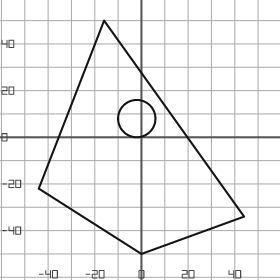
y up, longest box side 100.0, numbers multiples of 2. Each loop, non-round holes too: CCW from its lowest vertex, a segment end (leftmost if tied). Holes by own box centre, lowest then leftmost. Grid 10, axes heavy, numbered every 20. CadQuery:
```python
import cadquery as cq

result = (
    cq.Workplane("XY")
    .moveTo(0.0, -50.0)
    .lineTo(44.0, -34.0)
    .lineTo(-16.0, 50.0)
    .lineTo(-44.0, -22.0)
    .close()
    .moveTo(-2.0, 8.0)
    .circle(8.0)
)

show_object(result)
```